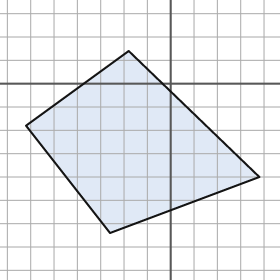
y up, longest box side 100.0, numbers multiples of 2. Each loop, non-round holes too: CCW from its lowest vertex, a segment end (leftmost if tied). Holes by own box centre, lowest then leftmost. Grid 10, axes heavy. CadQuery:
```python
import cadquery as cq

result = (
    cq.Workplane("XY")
    .moveTo(-26.0, -64.0)
    .lineTo(38.0, -40.0)
    .lineTo(-18.0, 14.0)
    .lineTo(-62.0, -18.0)
    .close()
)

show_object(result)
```